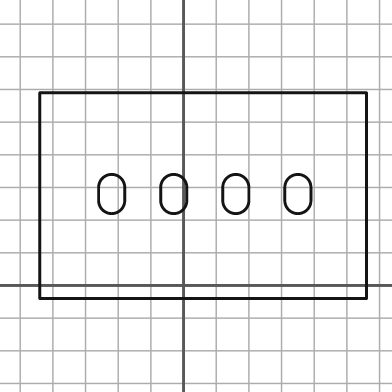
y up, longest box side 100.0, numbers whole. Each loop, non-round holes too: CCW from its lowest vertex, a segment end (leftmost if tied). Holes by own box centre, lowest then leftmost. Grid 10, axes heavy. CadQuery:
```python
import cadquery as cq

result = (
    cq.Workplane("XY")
    .moveTo(-44.0, -4.0)
    .lineTo(56.0, -4.0)
    .lineTo(56.0, 59.0)
    .lineTo(-44.0, 59.0)
    .close()
    .moveTo(-26.0, 26.0)
    .threePointArc((-22.0, 22.0), (-18.0, 26.0))
    .lineTo(-18.0, 30.0)
    .threePointArc((-22.0, 34.0), (-26.0, 30.0))
    .close()
    .moveTo(-7.0, 26.0)
    .threePointArc((-3.0, 22.0), (1.0, 26.0))
    .lineTo(1.0, 30.0)
    .threePointArc((-3.0, 34.0), (-7.0, 30.0))
    .close()
    .moveTo(12.0, 26.0)
    .threePointArc((16.0, 22.0), (20.0, 26.0))
    .lineTo(20.0, 30.0)
    .threePointArc((16.0, 34.0), (12.0, 30.0))
    .close()
    .moveTo(31.0, 26.0)
    .threePointArc((35.0, 22.0), (39.0, 26.0))
    .lineTo(39.0, 30.0)
    .threePointArc((35.0, 34.0), (31.0, 30.0))
    .close()
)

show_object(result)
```